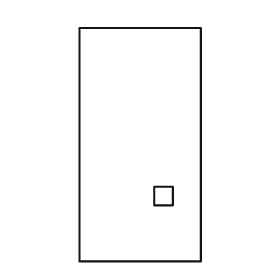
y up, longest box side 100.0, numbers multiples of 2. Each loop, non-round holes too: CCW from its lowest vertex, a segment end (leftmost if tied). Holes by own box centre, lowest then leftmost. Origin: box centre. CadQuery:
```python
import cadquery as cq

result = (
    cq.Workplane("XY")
    .moveTo(-26.0, -50.0)
    .lineTo(26.0, -50.0)
    .lineTo(26.0, 50.0)
    .lineTo(-26.0, 50.0)
    .close()
    .moveTo(6.0, -26.0)
    .lineTo(14.0, -26.0)
    .lineTo(14.0, -18.0)
    .lineTo(6.0, -18.0)
    .close()
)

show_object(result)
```